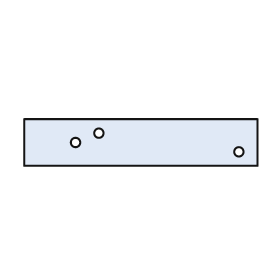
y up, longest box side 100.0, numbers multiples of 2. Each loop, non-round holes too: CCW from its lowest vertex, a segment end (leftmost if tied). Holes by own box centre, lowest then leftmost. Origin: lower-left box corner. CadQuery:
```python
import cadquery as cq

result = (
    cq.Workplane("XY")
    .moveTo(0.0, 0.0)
    .lineTo(100.0, 0.0)
    .lineTo(100.0, 20.0)
    .lineTo(0.0, 20.0)
    .close()
    .moveTo(92.0, 6.0)
    .circle(2.0)
    .moveTo(22.0, 10.0)
    .circle(2.0)
    .moveTo(32.0, 14.0)
    .circle(2.0)
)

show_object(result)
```